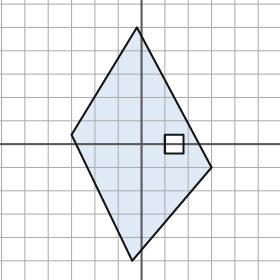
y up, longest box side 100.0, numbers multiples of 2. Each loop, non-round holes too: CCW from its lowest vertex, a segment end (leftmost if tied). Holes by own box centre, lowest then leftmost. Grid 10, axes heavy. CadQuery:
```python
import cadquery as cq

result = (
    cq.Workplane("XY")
    .moveTo(-4.0, -50.0)
    .lineTo(30.0, -10.0)
    .lineTo(-2.0, 50.0)
    .lineTo(-30.0, 4.0)
    .close()
    .moveTo(10.0, -4.0)
    .lineTo(18.0, -4.0)
    .lineTo(18.0, 4.0)
    .lineTo(10.0, 4.0)
    .close()
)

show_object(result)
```